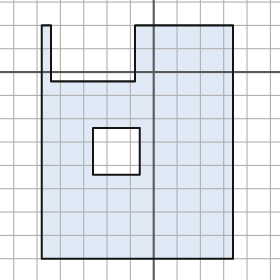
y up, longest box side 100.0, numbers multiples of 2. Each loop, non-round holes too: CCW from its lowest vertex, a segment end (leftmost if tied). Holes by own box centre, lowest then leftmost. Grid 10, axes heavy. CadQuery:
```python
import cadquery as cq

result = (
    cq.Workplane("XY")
    .moveTo(-48.0, -80.0)
    .lineTo(34.0, -80.0)
    .lineTo(34.0, 20.0)
    .lineTo(-8.0, 20.0)
    .lineTo(-8.0, -4.0)
    .lineTo(-44.0, -4.0)
    .lineTo(-44.0, 20.0)
    .lineTo(-48.0, 20.0)
    .close()
    .moveTo(-26.0, -44.0)
    .lineTo(-6.0, -44.0)
    .lineTo(-6.0, -24.0)
    .lineTo(-26.0, -24.0)
    .close()
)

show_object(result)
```